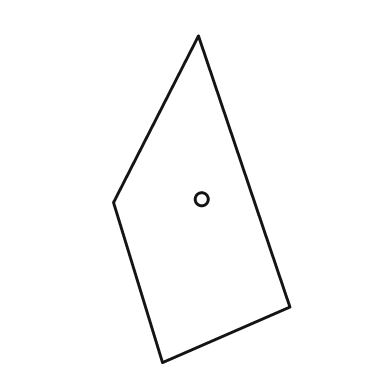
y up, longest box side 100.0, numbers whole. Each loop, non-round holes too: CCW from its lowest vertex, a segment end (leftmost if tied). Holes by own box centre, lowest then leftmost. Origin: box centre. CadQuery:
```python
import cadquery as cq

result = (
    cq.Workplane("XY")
    .moveTo(-12.0, -50.0)
    .lineTo(27.0, -33.0)
    .lineTo(-1.0, 50.0)
    .lineTo(-27.0, -1.0)
    .close()
    .moveTo(0.0, 0.0)
    .circle(2.0)
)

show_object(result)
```